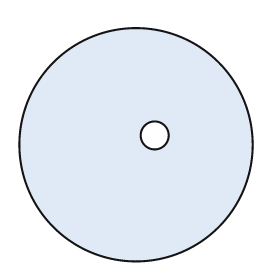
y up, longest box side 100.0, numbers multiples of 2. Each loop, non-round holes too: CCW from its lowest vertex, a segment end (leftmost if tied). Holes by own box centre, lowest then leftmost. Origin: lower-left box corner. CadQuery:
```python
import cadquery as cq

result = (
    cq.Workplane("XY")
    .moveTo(50.0, 50.0)
    .circle(50.0)
    .moveTo(58.0, 54.0)
    .circle(6.0)
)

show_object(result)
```